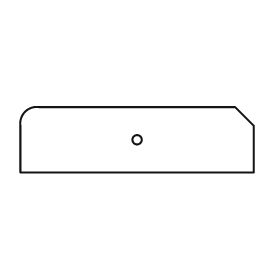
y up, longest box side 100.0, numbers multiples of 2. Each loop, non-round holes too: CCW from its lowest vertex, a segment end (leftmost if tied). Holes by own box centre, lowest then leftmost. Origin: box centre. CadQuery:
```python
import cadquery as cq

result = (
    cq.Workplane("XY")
    .moveTo(-50.0, -14.0)
    .lineTo(50.0, -14.0)
    .lineTo(50.0, 6.0)
    .lineTo(42.0, 14.0)
    .lineTo(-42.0, 14.0)
    .threePointArc((-48.0, 12.0), (-50.0, 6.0))
    .close()
    .moveTo(0.0, 0.0)
    .circle(2.0)
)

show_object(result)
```